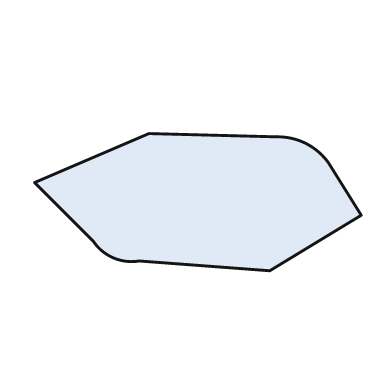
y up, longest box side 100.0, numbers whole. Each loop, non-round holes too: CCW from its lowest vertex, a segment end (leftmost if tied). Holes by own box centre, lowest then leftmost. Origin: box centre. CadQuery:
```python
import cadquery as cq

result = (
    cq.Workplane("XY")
    .moveTo(22.0, -21.0)
    .lineTo(50.0, -4.0)
    .lineTo(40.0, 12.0)
    .threePointArc((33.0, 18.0), (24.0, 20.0))
    .lineTo(-15.0, 21.0)
    .lineTo(-50.0, 6.0)
    .lineTo(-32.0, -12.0)
    .threePointArc((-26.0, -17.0), (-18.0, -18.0))
    .close()
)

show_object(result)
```